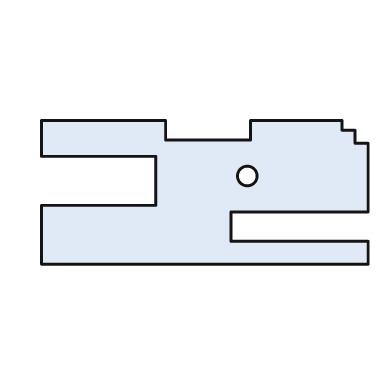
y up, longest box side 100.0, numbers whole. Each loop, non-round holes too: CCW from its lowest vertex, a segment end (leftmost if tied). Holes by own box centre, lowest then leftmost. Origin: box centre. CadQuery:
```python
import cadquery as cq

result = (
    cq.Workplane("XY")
    .moveTo(-50.0, -22.0)
    .lineTo(50.0, -22.0)
    .lineTo(50.0, -15.0)
    .lineTo(8.0, -15.0)
    .lineTo(8.0, -6.0)
    .lineTo(50.0, -6.0)
    .lineTo(50.0, 15.0)
    .lineTo(46.0, 15.0)
    .lineTo(46.0, 19.0)
    .lineTo(42.0, 19.0)
    .lineTo(42.0, 22.0)
    .lineTo(14.0, 22.0)
    .lineTo(14.0, 16.0)
    .lineTo(-12.0, 16.0)
    .lineTo(-12.0, 22.0)
    .lineTo(-50.0, 22.0)
    .lineTo(-50.0, 11.0)
    .lineTo(-15.0, 11.0)
    .lineTo(-15.0, -4.0)
    .lineTo(-50.0, -4.0)
    .close()
    .moveTo(13.0, 5.0)
    .circle(3.0)
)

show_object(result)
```